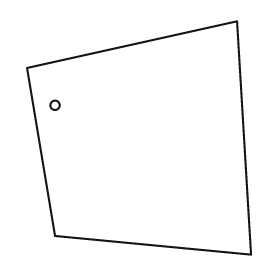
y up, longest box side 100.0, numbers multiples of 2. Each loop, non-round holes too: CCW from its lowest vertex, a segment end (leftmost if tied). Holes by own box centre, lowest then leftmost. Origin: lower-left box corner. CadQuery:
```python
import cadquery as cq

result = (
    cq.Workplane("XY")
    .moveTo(96.0, 0.0)
    .lineTo(90.0, 100.0)
    .lineTo(0.0, 80.0)
    .lineTo(12.0, 8.0)
    .close()
    .moveTo(12.0, 64.0)
    .circle(2.0)
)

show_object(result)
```